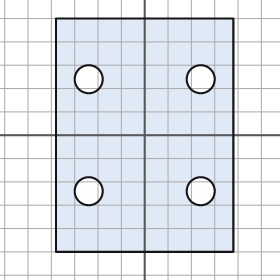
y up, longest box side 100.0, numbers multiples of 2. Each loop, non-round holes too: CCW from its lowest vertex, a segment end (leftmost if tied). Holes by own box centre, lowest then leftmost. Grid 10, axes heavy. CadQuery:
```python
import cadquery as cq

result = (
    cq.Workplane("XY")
    .moveTo(-38.0, -50.0)
    .lineTo(38.0, -50.0)
    .lineTo(38.0, 50.0)
    .lineTo(-38.0, 50.0)
    .close()
    .moveTo(-24.0, -24.0)
    .circle(6.0)
    .moveTo(24.0, -24.0)
    .circle(6.0)
    .moveTo(-24.0, 24.0)
    .circle(6.0)
    .moveTo(24.0, 24.0)
    .circle(6.0)
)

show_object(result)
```